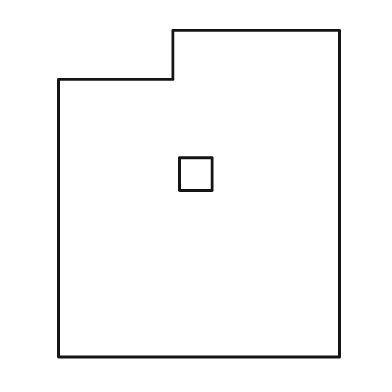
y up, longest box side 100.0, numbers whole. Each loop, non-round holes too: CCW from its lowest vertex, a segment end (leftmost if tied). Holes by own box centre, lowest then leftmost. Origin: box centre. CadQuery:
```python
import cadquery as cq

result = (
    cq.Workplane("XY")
    .moveTo(-43.0, -50.0)
    .lineTo(43.0, -50.0)
    .lineTo(43.0, 50.0)
    .lineTo(-8.0, 50.0)
    .lineTo(-8.0, 35.0)
    .lineTo(-43.0, 35.0)
    .close()
    .moveTo(-6.0, 1.0)
    .lineTo(4.0, 1.0)
    .lineTo(4.0, 11.0)
    .lineTo(-6.0, 11.0)
    .close()
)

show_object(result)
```